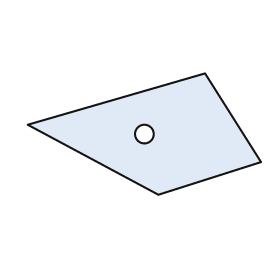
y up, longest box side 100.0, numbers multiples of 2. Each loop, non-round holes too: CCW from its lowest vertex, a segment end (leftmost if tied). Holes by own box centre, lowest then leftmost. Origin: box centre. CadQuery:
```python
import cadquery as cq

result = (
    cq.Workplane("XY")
    .moveTo(6.0, -26.0)
    .lineTo(50.0, -12.0)
    .lineTo(26.0, 26.0)
    .lineTo(-50.0, 4.0)
    .close()
    .moveTo(0.0, 0.0)
    .circle(4.0)
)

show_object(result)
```